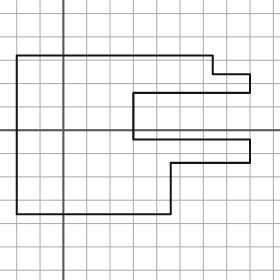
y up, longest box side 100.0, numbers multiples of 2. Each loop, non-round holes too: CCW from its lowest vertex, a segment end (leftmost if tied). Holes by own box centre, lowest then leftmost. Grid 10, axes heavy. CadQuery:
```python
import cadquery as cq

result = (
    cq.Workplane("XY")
    .moveTo(-20.0, -36.0)
    .lineTo(46.0, -36.0)
    .lineTo(46.0, -14.0)
    .lineTo(80.0, -14.0)
    .lineTo(80.0, -4.0)
    .lineTo(30.0, -4.0)
    .lineTo(30.0, 16.0)
    .lineTo(80.0, 16.0)
    .lineTo(80.0, 24.0)
    .lineTo(64.0, 24.0)
    .lineTo(64.0, 32.0)
    .lineTo(-20.0, 32.0)
    .close()
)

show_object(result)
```